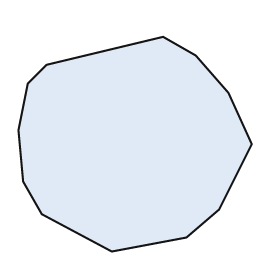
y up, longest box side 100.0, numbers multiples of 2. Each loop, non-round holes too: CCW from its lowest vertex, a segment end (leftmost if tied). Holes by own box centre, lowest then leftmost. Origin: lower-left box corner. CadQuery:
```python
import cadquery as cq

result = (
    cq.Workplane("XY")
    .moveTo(40.0, 0.0)
    .lineTo(72.0, 6.0)
    .lineTo(86.0, 18.0)
    .lineTo(100.0, 46.0)
    .lineTo(90.0, 68.0)
    .lineTo(76.0, 84.0)
    .lineTo(62.0, 92.0)
    .lineTo(12.0, 80.0)
    .lineTo(4.0, 72.0)
    .lineTo(0.0, 52.0)
    .lineTo(2.0, 30.0)
    .lineTo(10.0, 16.0)
    .close()
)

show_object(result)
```